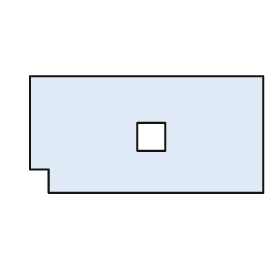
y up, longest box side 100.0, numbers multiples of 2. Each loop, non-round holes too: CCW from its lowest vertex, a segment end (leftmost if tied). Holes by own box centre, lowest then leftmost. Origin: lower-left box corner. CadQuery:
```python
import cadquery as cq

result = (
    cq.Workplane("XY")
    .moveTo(8.0, 0.0)
    .lineTo(100.0, 0.0)
    .lineTo(100.0, 50.0)
    .lineTo(0.0, 50.0)
    .lineTo(0.0, 10.0)
    .lineTo(8.0, 10.0)
    .close()
    .moveTo(46.0, 18.0)
    .lineTo(58.0, 18.0)
    .lineTo(58.0, 30.0)
    .lineTo(46.0, 30.0)
    .close()
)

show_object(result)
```